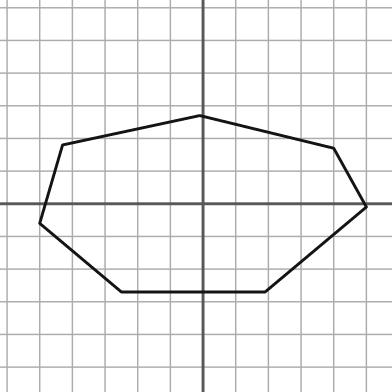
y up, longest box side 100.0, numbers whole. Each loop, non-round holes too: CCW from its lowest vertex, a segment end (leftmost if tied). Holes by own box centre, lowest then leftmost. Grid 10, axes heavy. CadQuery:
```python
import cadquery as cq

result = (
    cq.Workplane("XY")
    .moveTo(-25.0, -27.0)
    .lineTo(19.0, -27.0)
    .lineTo(50.0, -1.0)
    .lineTo(40.0, 17.0)
    .lineTo(-1.0, 27.0)
    .lineTo(-43.0, 18.0)
    .lineTo(-50.0, -6.0)
    .close()
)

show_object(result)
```